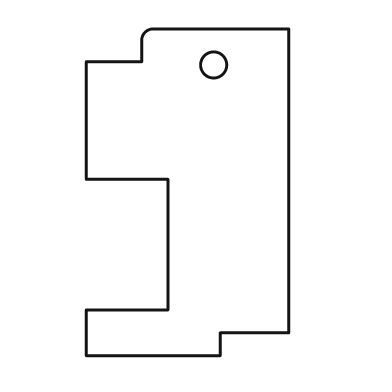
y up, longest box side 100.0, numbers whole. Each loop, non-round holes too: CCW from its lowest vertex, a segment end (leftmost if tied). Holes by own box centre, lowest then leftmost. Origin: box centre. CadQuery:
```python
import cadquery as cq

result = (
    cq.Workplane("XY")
    .moveTo(-31.0, -50.0)
    .lineTo(10.0, -50.0)
    .lineTo(10.0, -43.0)
    .lineTo(31.0, -43.0)
    .lineTo(31.0, 50.0)
    .lineTo(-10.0, 50.0)
    .threePointArc((-13.0, 49.0), (-14.0, 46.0))
    .lineTo(-14.0, 40.0)
    .lineTo(-31.0, 40.0)
    .lineTo(-31.0, 4.0)
    .lineTo(-6.0, 4.0)
    .lineTo(-6.0, -36.0)
    .lineTo(-31.0, -36.0)
    .close()
    .moveTo(8.0, 39.0)
    .circle(4.0)
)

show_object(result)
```